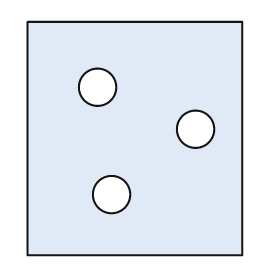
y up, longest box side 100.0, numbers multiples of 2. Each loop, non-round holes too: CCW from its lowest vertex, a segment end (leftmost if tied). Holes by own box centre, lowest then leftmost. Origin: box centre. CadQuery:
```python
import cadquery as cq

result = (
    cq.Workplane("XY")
    .moveTo(-46.0, -50.0)
    .lineTo(46.0, -50.0)
    .lineTo(46.0, 50.0)
    .lineTo(-46.0, 50.0)
    .close()
    .moveTo(-10.0, -24.0)
    .circle(8.0)
    .moveTo(26.0, 4.0)
    .circle(8.0)
    .moveTo(-16.0, 22.0)
    .circle(8.0)
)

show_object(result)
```